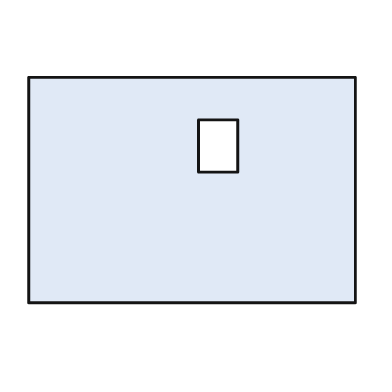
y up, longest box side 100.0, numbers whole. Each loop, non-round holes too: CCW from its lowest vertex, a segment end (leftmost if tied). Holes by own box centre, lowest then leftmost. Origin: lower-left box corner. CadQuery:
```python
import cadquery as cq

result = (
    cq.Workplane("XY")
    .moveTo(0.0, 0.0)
    .lineTo(100.0, 0.0)
    .lineTo(100.0, 69.0)
    .lineTo(0.0, 69.0)
    .close()
    .moveTo(52.0, 40.0)
    .lineTo(64.0, 40.0)
    .lineTo(64.0, 56.0)
    .lineTo(52.0, 56.0)
    .close()
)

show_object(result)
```